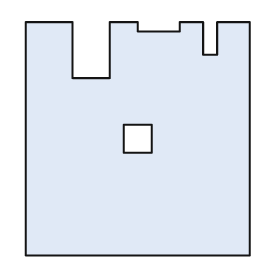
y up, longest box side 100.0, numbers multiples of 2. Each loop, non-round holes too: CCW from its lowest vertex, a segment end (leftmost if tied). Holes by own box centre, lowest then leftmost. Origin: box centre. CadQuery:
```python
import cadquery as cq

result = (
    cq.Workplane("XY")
    .moveTo(-48.0, -50.0)
    .lineTo(48.0, -50.0)
    .lineTo(48.0, 50.0)
    .lineTo(34.0, 50.0)
    .lineTo(34.0, 36.0)
    .lineTo(28.0, 36.0)
    .lineTo(28.0, 50.0)
    .lineTo(18.0, 50.0)
    .lineTo(18.0, 46.0)
    .lineTo(0.0, 46.0)
    .lineTo(0.0, 50.0)
    .lineTo(-12.0, 50.0)
    .lineTo(-12.0, 26.0)
    .lineTo(-28.0, 26.0)
    .lineTo(-28.0, 50.0)
    .lineTo(-48.0, 50.0)
    .close()
    .moveTo(-6.0, -6.0)
    .lineTo(6.0, -6.0)
    .lineTo(6.0, 6.0)
    .lineTo(-6.0, 6.0)
    .close()
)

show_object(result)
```